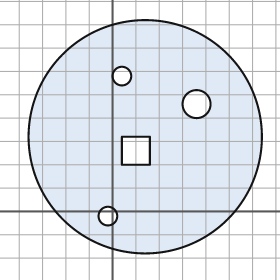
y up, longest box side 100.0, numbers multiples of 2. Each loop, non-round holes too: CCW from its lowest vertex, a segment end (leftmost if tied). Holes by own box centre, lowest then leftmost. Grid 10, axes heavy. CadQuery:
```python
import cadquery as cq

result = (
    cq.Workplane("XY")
    .moveTo(14.0, 32.0)
    .circle(50.0)
    .moveTo(-2.0, -2.0)
    .circle(4.0)
    .moveTo(4.0, 20.0)
    .lineTo(16.0, 20.0)
    .lineTo(16.0, 32.0)
    .lineTo(4.0, 32.0)
    .close()
    .moveTo(36.0, 46.0)
    .circle(6.0)
    .moveTo(4.0, 58.0)
    .circle(4.0)
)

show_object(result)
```